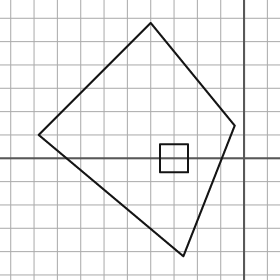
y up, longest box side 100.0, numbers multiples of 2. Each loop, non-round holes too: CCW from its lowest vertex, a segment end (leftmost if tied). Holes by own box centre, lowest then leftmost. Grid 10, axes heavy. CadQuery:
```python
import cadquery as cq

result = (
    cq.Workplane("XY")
    .moveTo(-26.0, -42.0)
    .lineTo(-4.0, 14.0)
    .lineTo(-40.0, 58.0)
    .lineTo(-88.0, 10.0)
    .close()
    .moveTo(-36.0, -6.0)
    .lineTo(-24.0, -6.0)
    .lineTo(-24.0, 6.0)
    .lineTo(-36.0, 6.0)
    .close()
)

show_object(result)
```